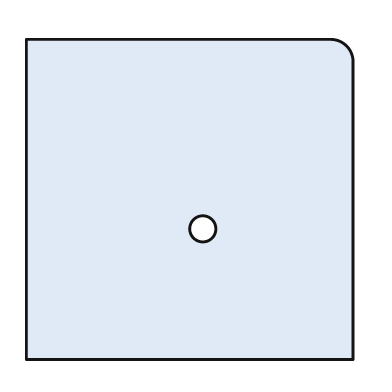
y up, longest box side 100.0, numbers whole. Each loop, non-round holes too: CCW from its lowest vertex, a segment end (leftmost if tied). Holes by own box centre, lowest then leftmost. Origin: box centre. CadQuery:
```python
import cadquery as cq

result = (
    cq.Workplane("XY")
    .moveTo(-50.0, -49.0)
    .lineTo(50.0, -49.0)
    .lineTo(50.0, 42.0)
    .threePointArc((48.0, 47.0), (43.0, 49.0))
    .lineTo(-50.0, 49.0)
    .close()
    .moveTo(4.0, -9.0)
    .circle(4.0)
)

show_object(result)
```